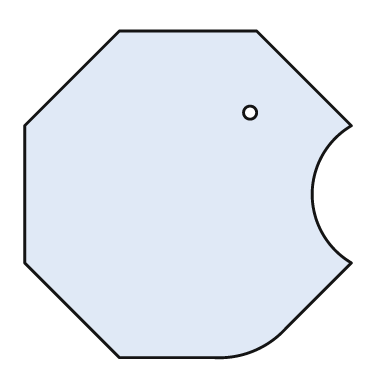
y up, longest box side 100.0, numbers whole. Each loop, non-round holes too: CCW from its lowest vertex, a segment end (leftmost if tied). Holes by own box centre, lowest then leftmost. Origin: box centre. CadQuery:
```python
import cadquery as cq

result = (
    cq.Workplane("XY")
    .moveTo(-21.0, -50.0)
    .lineTo(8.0, -50.0)
    .threePointArc((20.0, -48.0), (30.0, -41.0))
    .lineTo(50.0, -21.0)
    .threePointArc((38.0, 0.0), (50.0, 21.0))
    .lineTo(21.0, 50.0)
    .lineTo(-21.0, 50.0)
    .lineTo(-50.0, 21.0)
    .lineTo(-50.0, -21.0)
    .close()
    .moveTo(19.0, 25.0)
    .circle(2.0)
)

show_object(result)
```